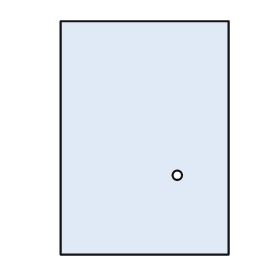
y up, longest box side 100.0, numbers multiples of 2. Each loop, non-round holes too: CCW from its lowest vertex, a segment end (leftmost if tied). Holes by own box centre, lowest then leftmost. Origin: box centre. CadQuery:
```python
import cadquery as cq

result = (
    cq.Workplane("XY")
    .moveTo(-36.0, -50.0)
    .lineTo(36.0, -50.0)
    .lineTo(36.0, 50.0)
    .lineTo(-36.0, 50.0)
    .close()
    .moveTo(14.0, -16.0)
    .circle(2.0)
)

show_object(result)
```